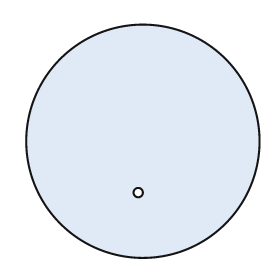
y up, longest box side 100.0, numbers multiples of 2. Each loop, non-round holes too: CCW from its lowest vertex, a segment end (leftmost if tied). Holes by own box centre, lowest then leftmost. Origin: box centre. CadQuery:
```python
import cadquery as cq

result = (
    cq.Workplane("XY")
    .moveTo(0.0, 0.0)
    .circle(50.0)
    .moveTo(-2.0, -22.0)
    .circle(2.0)
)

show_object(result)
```